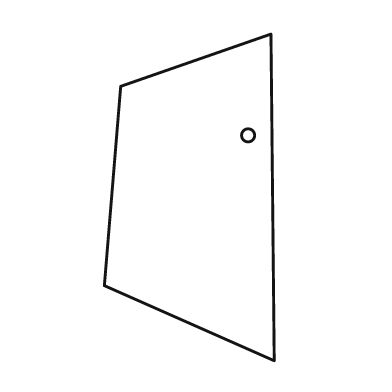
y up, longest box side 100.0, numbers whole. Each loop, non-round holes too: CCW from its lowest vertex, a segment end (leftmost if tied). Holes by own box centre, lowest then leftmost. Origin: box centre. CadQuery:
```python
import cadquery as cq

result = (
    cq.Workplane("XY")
    .moveTo(26.0, -50.0)
    .lineTo(25.0, 50.0)
    .lineTo(-21.0, 34.0)
    .lineTo(-26.0, -27.0)
    .close()
    .moveTo(18.0, 19.0)
    .circle(2.0)
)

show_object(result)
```